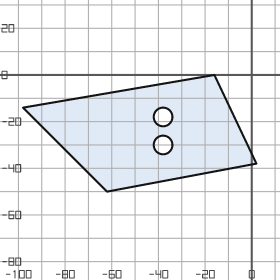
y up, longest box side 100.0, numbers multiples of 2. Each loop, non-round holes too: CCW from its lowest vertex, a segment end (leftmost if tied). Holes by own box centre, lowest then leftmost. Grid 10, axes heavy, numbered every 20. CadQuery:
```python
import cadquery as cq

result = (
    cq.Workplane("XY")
    .moveTo(-62.0, -50.0)
    .lineTo(2.0, -38.0)
    .lineTo(-16.0, 0.0)
    .lineTo(-98.0, -14.0)
    .close()
    .moveTo(-38.0, -30.0)
    .circle(4.0)
    .moveTo(-38.0, -18.0)
    .circle(4.0)
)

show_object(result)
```